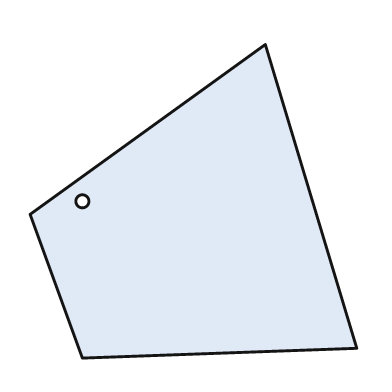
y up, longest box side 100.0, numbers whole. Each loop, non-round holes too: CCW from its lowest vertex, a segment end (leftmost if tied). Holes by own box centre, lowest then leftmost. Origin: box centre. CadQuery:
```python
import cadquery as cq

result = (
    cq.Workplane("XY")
    .moveTo(-34.0, -48.0)
    .lineTo(50.0, -45.0)
    .lineTo(22.0, 48.0)
    .lineTo(-50.0, -4.0)
    .close()
    .moveTo(-34.0, 0.0)
    .circle(2.0)
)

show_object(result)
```